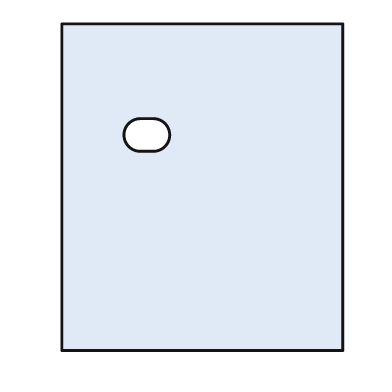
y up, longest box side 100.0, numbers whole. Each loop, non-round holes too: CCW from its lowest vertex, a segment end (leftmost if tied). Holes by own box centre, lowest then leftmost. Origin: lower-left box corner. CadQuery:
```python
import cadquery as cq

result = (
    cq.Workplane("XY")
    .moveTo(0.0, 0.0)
    .lineTo(86.0, 0.0)
    .lineTo(86.0, 100.0)
    .lineTo(0.0, 100.0)
    .close()
    .moveTo(24.0, 61.0)
    .lineTo(28.0, 61.0)
    .threePointArc((33.0, 66.0), (28.0, 71.0))
    .lineTo(24.0, 71.0)
    .threePointArc((19.0, 66.0), (24.0, 61.0))
    .close()
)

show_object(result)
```